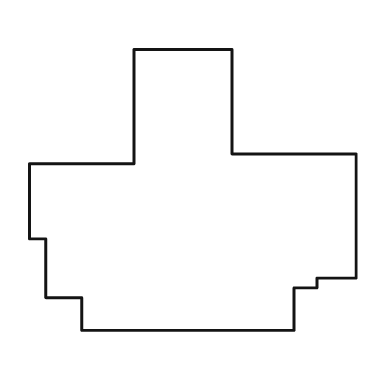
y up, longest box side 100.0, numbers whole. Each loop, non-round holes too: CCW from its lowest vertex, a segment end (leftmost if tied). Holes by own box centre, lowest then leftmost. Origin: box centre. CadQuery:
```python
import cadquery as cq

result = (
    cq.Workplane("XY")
    .moveTo(-34.0, -43.0)
    .lineTo(31.0, -43.0)
    .lineTo(31.0, -30.0)
    .lineTo(38.0, -30.0)
    .lineTo(38.0, -27.0)
    .lineTo(50.0, -27.0)
    .lineTo(50.0, 11.0)
    .lineTo(12.0, 11.0)
    .lineTo(12.0, 43.0)
    .lineTo(-18.0, 43.0)
    .lineTo(-18.0, 8.0)
    .lineTo(-50.0, 8.0)
    .lineTo(-50.0, -15.0)
    .lineTo(-45.0, -15.0)
    .lineTo(-45.0, -33.0)
    .lineTo(-34.0, -33.0)
    .close()
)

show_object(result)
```